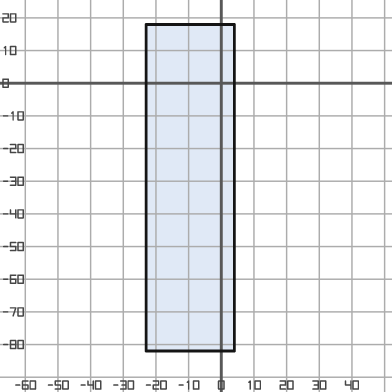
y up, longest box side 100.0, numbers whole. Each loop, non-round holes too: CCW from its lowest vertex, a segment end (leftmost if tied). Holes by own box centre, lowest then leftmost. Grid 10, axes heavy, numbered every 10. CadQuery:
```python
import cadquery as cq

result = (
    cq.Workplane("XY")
    .moveTo(-23.0, -82.0)
    .lineTo(4.0, -82.0)
    .lineTo(4.0, 18.0)
    .lineTo(-23.0, 18.0)
    .close()
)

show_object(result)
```